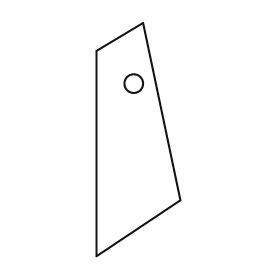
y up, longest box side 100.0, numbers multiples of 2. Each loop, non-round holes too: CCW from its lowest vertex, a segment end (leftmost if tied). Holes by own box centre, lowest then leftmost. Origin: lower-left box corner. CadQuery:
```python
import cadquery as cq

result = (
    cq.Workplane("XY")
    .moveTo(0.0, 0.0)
    .lineTo(36.0, 24.0)
    .lineTo(20.0, 100.0)
    .lineTo(0.0, 88.0)
    .close()
    .moveTo(16.0, 74.0)
    .circle(4.0)
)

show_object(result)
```